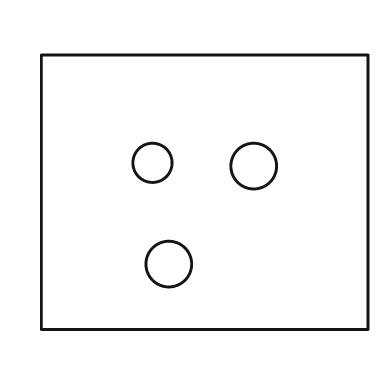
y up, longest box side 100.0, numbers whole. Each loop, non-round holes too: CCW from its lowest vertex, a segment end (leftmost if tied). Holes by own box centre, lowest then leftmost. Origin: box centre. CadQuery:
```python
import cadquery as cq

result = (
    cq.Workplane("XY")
    .moveTo(-50.0, -42.0)
    .lineTo(50.0, -42.0)
    .lineTo(50.0, 42.0)
    .lineTo(-50.0, 42.0)
    .close()
    .moveTo(-11.0, -22.0)
    .circle(7.0)
    .moveTo(15.0, 8.0)
    .circle(7.0)
    .moveTo(-16.0, 9.0)
    .circle(6.0)
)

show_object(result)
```